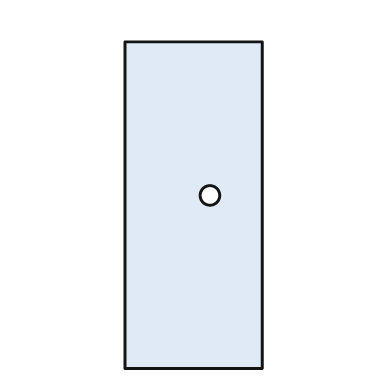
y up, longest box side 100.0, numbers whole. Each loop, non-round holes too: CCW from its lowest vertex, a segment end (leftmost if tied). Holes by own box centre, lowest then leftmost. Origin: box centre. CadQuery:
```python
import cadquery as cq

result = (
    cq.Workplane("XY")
    .moveTo(-21.0, -50.0)
    .lineTo(21.0, -50.0)
    .lineTo(21.0, 50.0)
    .lineTo(-21.0, 50.0)
    .close()
    .moveTo(5.0, 3.0)
    .circle(3.0)
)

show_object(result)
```